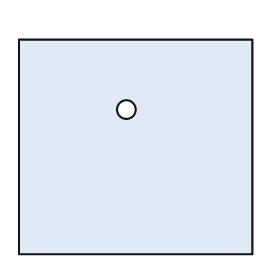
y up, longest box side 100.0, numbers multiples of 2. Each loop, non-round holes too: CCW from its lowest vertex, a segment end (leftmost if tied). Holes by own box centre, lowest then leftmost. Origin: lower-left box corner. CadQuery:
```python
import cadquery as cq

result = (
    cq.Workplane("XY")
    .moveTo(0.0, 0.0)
    .lineTo(100.0, 0.0)
    .lineTo(100.0, 92.0)
    .lineTo(0.0, 92.0)
    .close()
    .moveTo(46.0, 62.0)
    .circle(4.0)
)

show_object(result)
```